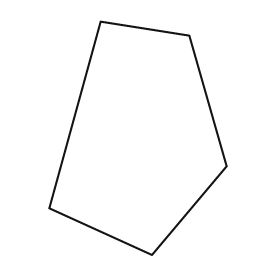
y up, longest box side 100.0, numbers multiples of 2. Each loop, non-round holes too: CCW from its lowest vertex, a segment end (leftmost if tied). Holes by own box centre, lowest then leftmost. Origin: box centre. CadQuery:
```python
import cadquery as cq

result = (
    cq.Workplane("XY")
    .moveTo(6.0, -50.0)
    .lineTo(38.0, -12.0)
    .lineTo(22.0, 44.0)
    .lineTo(-16.0, 50.0)
    .lineTo(-38.0, -30.0)
    .close()
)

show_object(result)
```